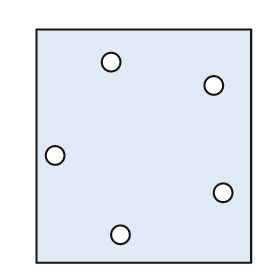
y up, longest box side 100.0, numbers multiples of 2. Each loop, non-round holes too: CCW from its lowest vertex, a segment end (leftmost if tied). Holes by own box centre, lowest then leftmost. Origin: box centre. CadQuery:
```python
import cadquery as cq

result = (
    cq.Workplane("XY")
    .moveTo(-46.0, -50.0)
    .lineTo(46.0, -50.0)
    .lineTo(46.0, 50.0)
    .lineTo(-46.0, 50.0)
    .close()
    .moveTo(-10.0, -38.0)
    .circle(4.0)
    .moveTo(34.0, -20.0)
    .circle(4.0)
    .moveTo(-38.0, -4.0)
    .circle(4.0)
    .moveTo(30.0, 26.0)
    .circle(4.0)
    .moveTo(-14.0, 36.0)
    .circle(4.0)
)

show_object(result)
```